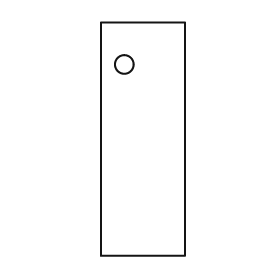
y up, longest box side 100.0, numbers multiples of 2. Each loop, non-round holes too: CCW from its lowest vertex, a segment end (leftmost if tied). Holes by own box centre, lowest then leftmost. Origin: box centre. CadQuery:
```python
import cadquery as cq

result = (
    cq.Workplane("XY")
    .moveTo(-18.0, -50.0)
    .lineTo(18.0, -50.0)
    .lineTo(18.0, 50.0)
    .lineTo(-18.0, 50.0)
    .close()
    .moveTo(-8.0, 32.0)
    .circle(4.0)
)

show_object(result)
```